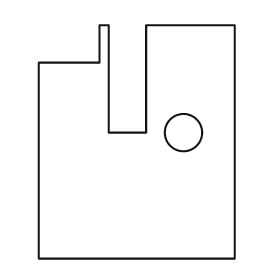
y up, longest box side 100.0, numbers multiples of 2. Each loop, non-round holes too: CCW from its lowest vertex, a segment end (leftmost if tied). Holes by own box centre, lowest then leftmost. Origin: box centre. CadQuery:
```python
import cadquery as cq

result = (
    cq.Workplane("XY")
    .moveTo(-42.0, -50.0)
    .lineTo(42.0, -50.0)
    .lineTo(42.0, 50.0)
    .lineTo(4.0, 50.0)
    .lineTo(4.0, 4.0)
    .lineTo(-12.0, 4.0)
    .lineTo(-12.0, 50.0)
    .lineTo(-16.0, 50.0)
    .lineTo(-16.0, 34.0)
    .lineTo(-42.0, 34.0)
    .close()
    .moveTo(20.0, 4.0)
    .circle(8.0)
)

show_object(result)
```